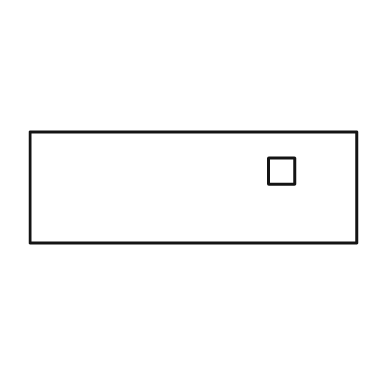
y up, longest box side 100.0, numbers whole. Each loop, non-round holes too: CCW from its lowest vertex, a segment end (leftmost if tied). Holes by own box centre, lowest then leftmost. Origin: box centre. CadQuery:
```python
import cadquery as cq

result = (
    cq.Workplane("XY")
    .moveTo(-50.0, -17.0)
    .lineTo(50.0, -17.0)
    .lineTo(50.0, 17.0)
    .lineTo(-50.0, 17.0)
    .close()
    .moveTo(23.0, 1.0)
    .lineTo(31.0, 1.0)
    .lineTo(31.0, 9.0)
    .lineTo(23.0, 9.0)
    .close()
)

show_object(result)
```